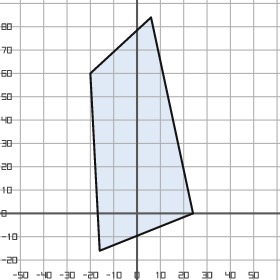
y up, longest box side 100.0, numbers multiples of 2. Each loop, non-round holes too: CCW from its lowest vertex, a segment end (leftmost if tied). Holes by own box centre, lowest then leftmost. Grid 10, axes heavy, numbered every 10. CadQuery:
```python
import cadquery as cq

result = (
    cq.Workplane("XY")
    .moveTo(-16.0, -16.0)
    .lineTo(24.0, 0.0)
    .lineTo(6.0, 84.0)
    .lineTo(-20.0, 60.0)
    .close()
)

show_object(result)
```